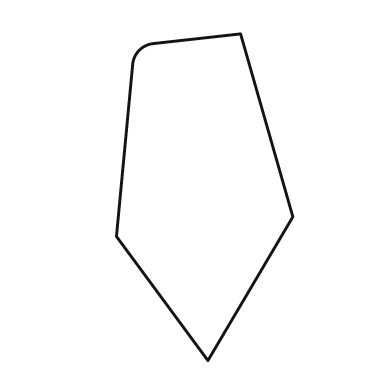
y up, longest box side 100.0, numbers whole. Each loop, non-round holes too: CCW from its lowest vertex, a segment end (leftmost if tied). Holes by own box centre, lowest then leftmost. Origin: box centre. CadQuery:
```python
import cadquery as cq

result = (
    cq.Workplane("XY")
    .moveTo(1.0, -50.0)
    .lineTo(27.0, -6.0)
    .lineTo(11.0, 50.0)
    .lineTo(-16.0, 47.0)
    .threePointArc((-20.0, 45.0), (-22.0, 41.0))
    .lineTo(-27.0, -12.0)
    .close()
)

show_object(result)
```